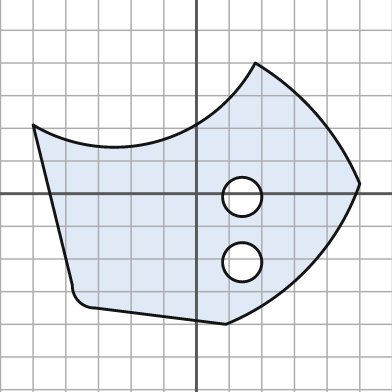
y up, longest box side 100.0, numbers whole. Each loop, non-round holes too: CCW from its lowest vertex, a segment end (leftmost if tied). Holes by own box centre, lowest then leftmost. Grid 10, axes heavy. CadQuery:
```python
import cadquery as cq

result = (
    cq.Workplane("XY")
    .moveTo(9.0, -40.0)
    .threePointArc((34.0, -23.0), (50.0, 3.0))
    .threePointArc((37.0, 24.0), (18.0, 40.0))
    .threePointArc((-12.0, 16.0), (-50.0, 21.0))
    .lineTo(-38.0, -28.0)
    .threePointArc((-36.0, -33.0), (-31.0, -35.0))
    .close()
    .moveTo(14.0, -21.0)
    .circle(6.0)
    .moveTo(14.0, -1.0)
    .circle(6.0)
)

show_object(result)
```